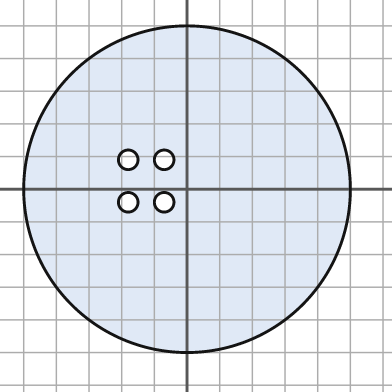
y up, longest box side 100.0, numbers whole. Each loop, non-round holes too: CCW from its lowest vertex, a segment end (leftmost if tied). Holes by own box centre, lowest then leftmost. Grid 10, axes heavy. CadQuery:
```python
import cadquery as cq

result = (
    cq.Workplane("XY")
    .moveTo(0.0, 0.0)
    .circle(50.0)
    .moveTo(-18.0, -4.0)
    .circle(3.0)
    .moveTo(-7.0, -4.0)
    .circle(3.0)
    .moveTo(-18.0, 9.0)
    .circle(3.0)
    .moveTo(-7.0, 9.0)
    .circle(3.0)
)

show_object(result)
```